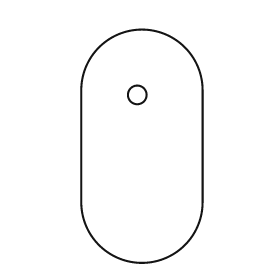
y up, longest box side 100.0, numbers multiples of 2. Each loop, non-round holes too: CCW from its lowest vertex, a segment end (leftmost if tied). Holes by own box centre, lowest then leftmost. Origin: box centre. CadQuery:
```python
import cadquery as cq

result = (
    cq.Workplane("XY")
    .moveTo(-26.0, -24.0)
    .threePointArc((0.0, -50.0), (26.0, -24.0))
    .lineTo(26.0, 24.0)
    .threePointArc((0.0, 50.0), (-26.0, 24.0))
    .close()
    .moveTo(-2.0, 22.0)
    .circle(4.0)
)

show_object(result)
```